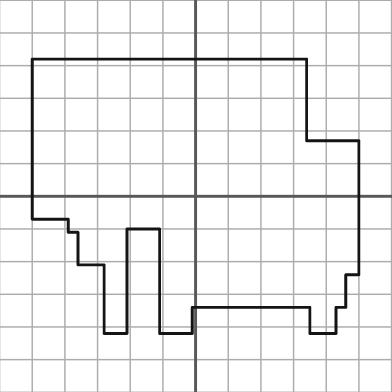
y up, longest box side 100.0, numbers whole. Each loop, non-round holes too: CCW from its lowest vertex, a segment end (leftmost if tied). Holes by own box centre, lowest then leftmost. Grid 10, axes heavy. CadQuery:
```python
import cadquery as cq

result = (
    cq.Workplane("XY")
    .moveTo(-28.0, -42.0)
    .lineTo(-21.0, -42.0)
    .lineTo(-21.0, -10.0)
    .lineTo(-11.0, -10.0)
    .lineTo(-11.0, -42.0)
    .lineTo(-1.0, -42.0)
    .lineTo(-1.0, -34.0)
    .lineTo(35.0, -34.0)
    .lineTo(35.0, -42.0)
    .lineTo(43.0, -42.0)
    .lineTo(43.0, -34.0)
    .lineTo(46.0, -34.0)
    .lineTo(46.0, -24.0)
    .lineTo(50.0, -24.0)
    .lineTo(50.0, 17.0)
    .lineTo(34.0, 17.0)
    .lineTo(34.0, 42.0)
    .lineTo(-50.0, 42.0)
    .lineTo(-50.0, -7.0)
    .lineTo(-39.0, -7.0)
    .lineTo(-39.0, -11.0)
    .lineTo(-36.0, -11.0)
    .lineTo(-36.0, -21.0)
    .lineTo(-28.0, -21.0)
    .close()
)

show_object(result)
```